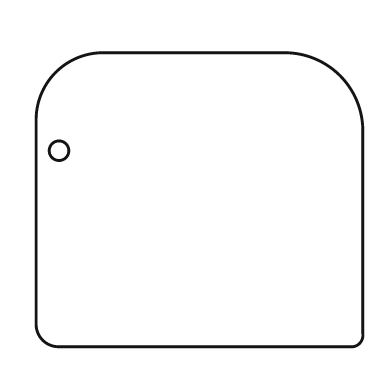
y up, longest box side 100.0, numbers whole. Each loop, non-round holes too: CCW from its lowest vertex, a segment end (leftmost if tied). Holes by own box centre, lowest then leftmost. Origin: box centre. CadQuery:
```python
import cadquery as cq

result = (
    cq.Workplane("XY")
    .moveTo(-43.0, -45.0)
    .lineTo(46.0, -45.0)
    .threePointArc((49.0, -44.0), (50.0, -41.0))
    .lineTo(50.0, 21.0)
    .threePointArc((43.0, 38.0), (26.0, 45.0))
    .lineTo(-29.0, 45.0)
    .threePointArc((-44.0, 39.0), (-50.0, 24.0))
    .lineTo(-50.0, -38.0)
    .threePointArc((-48.0, -43.0), (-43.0, -45.0))
    .close()
    .moveTo(-43.0, 15.0)
    .circle(3.0)
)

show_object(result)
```